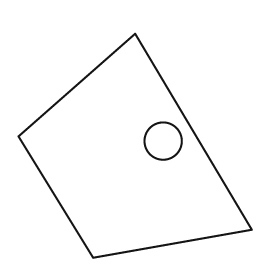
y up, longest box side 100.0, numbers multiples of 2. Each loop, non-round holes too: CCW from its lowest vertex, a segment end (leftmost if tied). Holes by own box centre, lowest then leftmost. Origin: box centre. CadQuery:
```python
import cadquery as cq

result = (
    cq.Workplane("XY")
    .moveTo(-18.0, -48.0)
    .lineTo(50.0, -36.0)
    .lineTo(0.0, 48.0)
    .lineTo(-50.0, 4.0)
    .close()
    .moveTo(12.0, 2.0)
    .circle(8.0)
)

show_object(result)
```